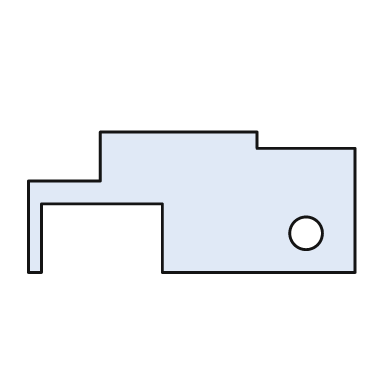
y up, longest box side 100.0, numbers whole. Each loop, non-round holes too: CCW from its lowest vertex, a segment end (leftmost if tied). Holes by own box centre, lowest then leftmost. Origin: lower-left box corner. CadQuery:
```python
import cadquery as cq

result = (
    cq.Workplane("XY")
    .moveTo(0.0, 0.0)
    .lineTo(4.0, 0.0)
    .lineTo(4.0, 21.0)
    .lineTo(41.0, 21.0)
    .lineTo(41.0, 0.0)
    .lineTo(100.0, 0.0)
    .lineTo(100.0, 38.0)
    .lineTo(70.0, 38.0)
    .lineTo(70.0, 43.0)
    .lineTo(22.0, 43.0)
    .lineTo(22.0, 28.0)
    .lineTo(0.0, 28.0)
    .close()
    .moveTo(85.0, 12.0)
    .circle(5.0)
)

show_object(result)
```